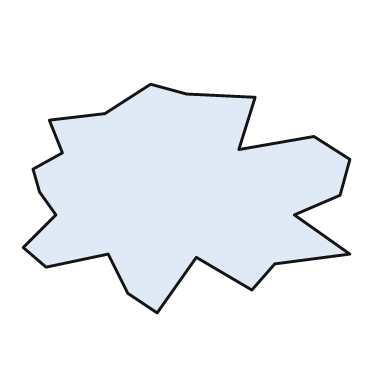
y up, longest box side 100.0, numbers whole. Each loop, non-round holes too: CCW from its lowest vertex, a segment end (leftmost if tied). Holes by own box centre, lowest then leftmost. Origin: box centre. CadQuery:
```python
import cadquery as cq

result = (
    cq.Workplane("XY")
    .moveTo(-9.0, -35.0)
    .lineTo(3.0, -18.0)
    .lineTo(20.0, -28.0)
    .lineTo(27.0, -20.0)
    .lineTo(50.0, -17.0)
    .lineTo(33.0, -5.0)
    .lineTo(47.0, 1.0)
    .lineTo(50.0, 12.0)
    .lineTo(39.0, 19.0)
    .lineTo(16.0, 15.0)
    .lineTo(21.0, 31.0)
    .lineTo(0.0, 32.0)
    .lineTo(-11.0, 35.0)
    .lineTo(-25.0, 26.0)
    .lineTo(-42.0, 24.0)
    .lineTo(-38.0, 14.0)
    .lineTo(-47.0, 9.0)
    .lineTo(-45.0, 2.0)
    .lineTo(-40.0, -5.0)
    .lineTo(-50.0, -15.0)
    .lineTo(-43.0, -21.0)
    .lineTo(-24.0, -17.0)
    .lineTo(-18.0, -29.0)
    .close()
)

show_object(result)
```